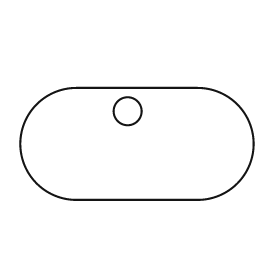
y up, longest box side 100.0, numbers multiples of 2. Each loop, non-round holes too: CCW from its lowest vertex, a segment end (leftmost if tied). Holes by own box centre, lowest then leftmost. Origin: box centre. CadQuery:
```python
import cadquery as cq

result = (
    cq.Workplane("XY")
    .moveTo(-26.0, -24.0)
    .lineTo(26.0, -24.0)
    .threePointArc((50.0, 0.0), (26.0, 24.0))
    .lineTo(-26.0, 24.0)
    .threePointArc((-50.0, 0.0), (-26.0, -24.0))
    .close()
    .moveTo(-4.0, 14.0)
    .circle(6.0)
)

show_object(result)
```